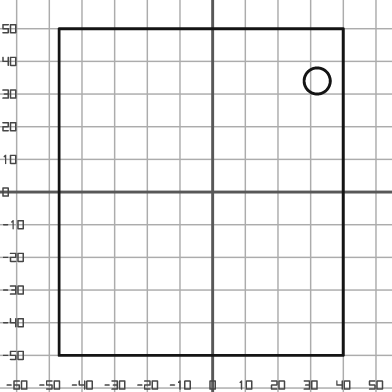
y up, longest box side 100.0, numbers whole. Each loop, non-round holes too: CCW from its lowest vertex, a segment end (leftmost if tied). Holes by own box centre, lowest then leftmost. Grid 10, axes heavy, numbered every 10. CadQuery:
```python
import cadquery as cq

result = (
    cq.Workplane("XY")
    .moveTo(-47.0, -50.0)
    .lineTo(40.0, -50.0)
    .lineTo(40.0, 50.0)
    .lineTo(-47.0, 50.0)
    .close()
    .moveTo(32.0, 34.0)
    .circle(4.0)
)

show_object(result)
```